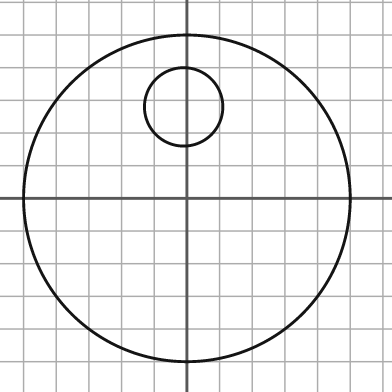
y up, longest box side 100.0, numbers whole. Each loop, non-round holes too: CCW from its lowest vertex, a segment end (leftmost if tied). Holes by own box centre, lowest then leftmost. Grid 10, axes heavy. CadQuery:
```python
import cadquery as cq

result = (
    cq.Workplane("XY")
    .moveTo(0.0, 0.0)
    .circle(50.0)
    .moveTo(-1.0, 28.0)
    .circle(12.0)
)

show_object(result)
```